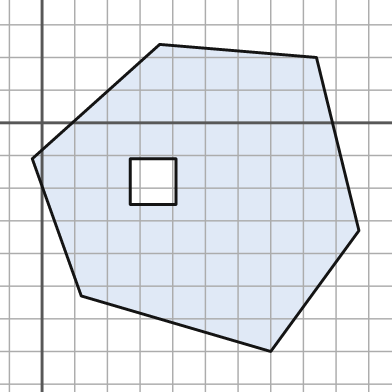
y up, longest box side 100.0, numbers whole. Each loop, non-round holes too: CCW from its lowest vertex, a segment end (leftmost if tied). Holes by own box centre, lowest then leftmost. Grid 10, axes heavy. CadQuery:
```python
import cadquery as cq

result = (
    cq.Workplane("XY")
    .moveTo(70.0, -70.0)
    .lineTo(97.0, -33.0)
    .lineTo(84.0, 20.0)
    .lineTo(36.0, 24.0)
    .lineTo(-3.0, -11.0)
    .lineTo(12.0, -53.0)
    .close()
    .moveTo(27.0, -25.0)
    .lineTo(41.0, -25.0)
    .lineTo(41.0, -11.0)
    .lineTo(27.0, -11.0)
    .close()
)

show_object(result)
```